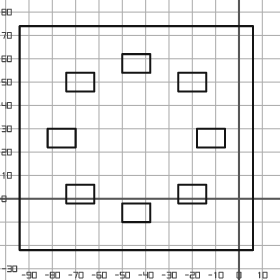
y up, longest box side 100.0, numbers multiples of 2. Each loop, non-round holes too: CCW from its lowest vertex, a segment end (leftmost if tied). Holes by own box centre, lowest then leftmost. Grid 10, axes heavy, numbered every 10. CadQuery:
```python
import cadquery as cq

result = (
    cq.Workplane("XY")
    .moveTo(-94.0, -22.0)
    .lineTo(6.0, -22.0)
    .lineTo(6.0, 74.0)
    .lineTo(-94.0, 74.0)
    .close()
    .moveTo(-50.0, -10.0)
    .lineTo(-38.0, -10.0)
    .lineTo(-38.0, -2.0)
    .lineTo(-50.0, -2.0)
    .close()
    .moveTo(-74.0, -2.0)
    .lineTo(-62.0, -2.0)
    .lineTo(-62.0, 6.0)
    .lineTo(-74.0, 6.0)
    .close()
    .moveTo(-26.0, -2.0)
    .lineTo(-14.0, -2.0)
    .lineTo(-14.0, 6.0)
    .lineTo(-26.0, 6.0)
    .close()
    .moveTo(-82.0, 22.0)
    .lineTo(-70.0, 22.0)
    .lineTo(-70.0, 30.0)
    .lineTo(-82.0, 30.0)
    .close()
    .moveTo(-18.0, 22.0)
    .lineTo(-6.0, 22.0)
    .lineTo(-6.0, 30.0)
    .lineTo(-18.0, 30.0)
    .close()
    .moveTo(-74.0, 46.0)
    .lineTo(-62.0, 46.0)
    .lineTo(-62.0, 54.0)
    .lineTo(-74.0, 54.0)
    .close()
    .moveTo(-26.0, 46.0)
    .lineTo(-14.0, 46.0)
    .lineTo(-14.0, 54.0)
    .lineTo(-26.0, 54.0)
    .close()
    .moveTo(-50.0, 54.0)
    .lineTo(-38.0, 54.0)
    .lineTo(-38.0, 62.0)
    .lineTo(-50.0, 62.0)
    .close()
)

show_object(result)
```